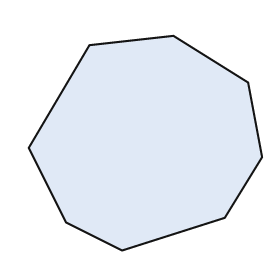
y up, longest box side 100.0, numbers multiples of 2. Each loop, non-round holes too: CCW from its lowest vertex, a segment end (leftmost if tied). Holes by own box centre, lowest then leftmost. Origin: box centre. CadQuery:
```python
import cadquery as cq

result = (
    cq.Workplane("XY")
    .moveTo(-10.0, -46.0)
    .lineTo(34.0, -32.0)
    .lineTo(50.0, -6.0)
    .lineTo(44.0, 26.0)
    .lineTo(12.0, 46.0)
    .lineTo(-24.0, 42.0)
    .lineTo(-50.0, -2.0)
    .lineTo(-34.0, -34.0)
    .close()
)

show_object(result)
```